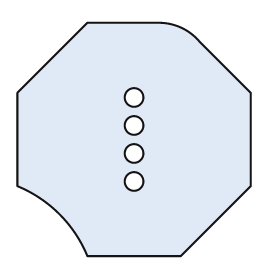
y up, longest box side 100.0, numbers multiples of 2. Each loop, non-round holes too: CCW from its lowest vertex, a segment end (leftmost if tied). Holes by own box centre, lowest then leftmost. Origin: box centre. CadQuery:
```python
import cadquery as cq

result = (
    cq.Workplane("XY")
    .moveTo(-20.0, -50.0)
    .lineTo(20.0, -50.0)
    .lineTo(50.0, -20.0)
    .lineTo(50.0, 20.0)
    .lineTo(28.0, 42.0)
    .threePointArc((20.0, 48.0), (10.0, 50.0))
    .lineTo(-20.0, 50.0)
    .lineTo(-50.0, 20.0)
    .lineTo(-50.0, -20.0)
    .threePointArc((-32.0, -32.0), (-20.0, -50.0))
    .close()
    .moveTo(0.0, -18.0)
    .circle(4.0)
    .moveTo(0.0, -6.0)
    .circle(4.0)
    .moveTo(0.0, 6.0)
    .circle(4.0)
    .moveTo(0.0, 18.0)
    .circle(4.0)
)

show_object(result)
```